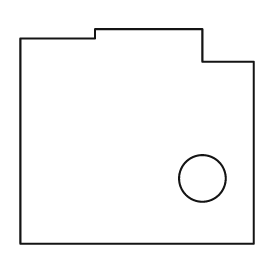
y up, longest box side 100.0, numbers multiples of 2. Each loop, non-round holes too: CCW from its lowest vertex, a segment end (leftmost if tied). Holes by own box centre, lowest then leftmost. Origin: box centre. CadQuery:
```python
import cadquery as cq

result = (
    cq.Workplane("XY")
    .moveTo(-50.0, -46.0)
    .lineTo(50.0, -46.0)
    .lineTo(50.0, 32.0)
    .lineTo(28.0, 32.0)
    .lineTo(28.0, 46.0)
    .lineTo(-18.0, 46.0)
    .lineTo(-18.0, 42.0)
    .lineTo(-50.0, 42.0)
    .close()
    .moveTo(28.0, -18.0)
    .circle(10.0)
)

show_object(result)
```